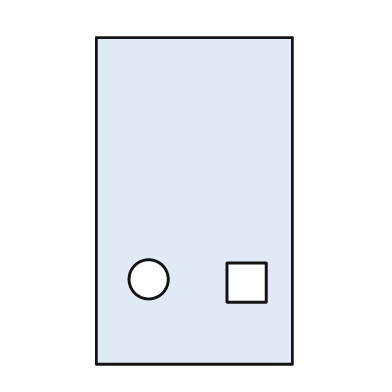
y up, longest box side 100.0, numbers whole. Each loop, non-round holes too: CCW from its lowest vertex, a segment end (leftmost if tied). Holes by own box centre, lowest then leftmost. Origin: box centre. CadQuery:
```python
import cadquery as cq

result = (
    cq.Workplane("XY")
    .moveTo(-30.0, -50.0)
    .lineTo(30.0, -50.0)
    .lineTo(30.0, 50.0)
    .lineTo(-30.0, 50.0)
    .close()
    .moveTo(10.0, -31.0)
    .lineTo(22.0, -31.0)
    .lineTo(22.0, -19.0)
    .lineTo(10.0, -19.0)
    .close()
    .moveTo(-14.0, -24.0)
    .circle(6.0)
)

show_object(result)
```